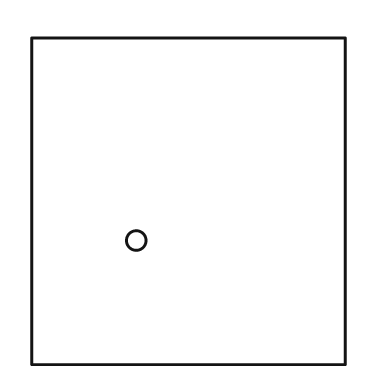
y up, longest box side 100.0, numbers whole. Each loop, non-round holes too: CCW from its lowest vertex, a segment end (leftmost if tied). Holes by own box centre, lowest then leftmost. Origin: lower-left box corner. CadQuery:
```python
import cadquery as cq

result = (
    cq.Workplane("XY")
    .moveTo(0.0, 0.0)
    .lineTo(96.0, 0.0)
    .lineTo(96.0, 100.0)
    .lineTo(0.0, 100.0)
    .close()
    .moveTo(32.0, 38.0)
    .circle(3.0)
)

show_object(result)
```